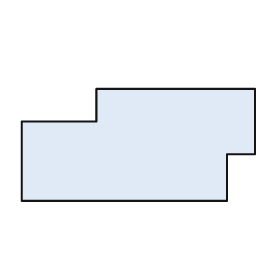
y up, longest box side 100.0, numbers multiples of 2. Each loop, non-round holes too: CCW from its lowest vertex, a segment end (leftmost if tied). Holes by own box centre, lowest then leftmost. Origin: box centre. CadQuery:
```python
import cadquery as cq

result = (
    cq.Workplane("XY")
    .moveTo(-50.0, -24.0)
    .lineTo(38.0, -24.0)
    .lineTo(38.0, -4.0)
    .lineTo(50.0, -4.0)
    .lineTo(50.0, 24.0)
    .lineTo(-18.0, 24.0)
    .lineTo(-18.0, 10.0)
    .lineTo(-50.0, 10.0)
    .close()
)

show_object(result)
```